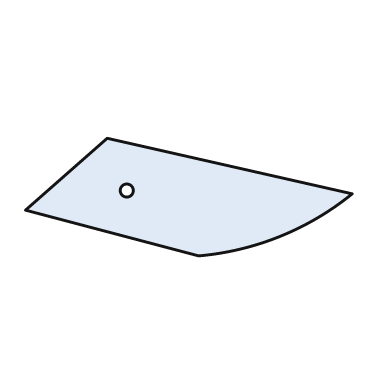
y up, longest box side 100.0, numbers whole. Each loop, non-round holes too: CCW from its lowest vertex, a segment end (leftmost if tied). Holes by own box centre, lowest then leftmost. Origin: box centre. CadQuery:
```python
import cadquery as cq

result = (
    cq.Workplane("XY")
    .moveTo(3.0, -18.0)
    .threePointArc((28.0, -12.0), (50.0, 1.0))
    .lineTo(-25.0, 18.0)
    .lineTo(-50.0, -4.0)
    .close()
    .moveTo(-19.0, 2.0)
    .circle(2.0)
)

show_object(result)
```